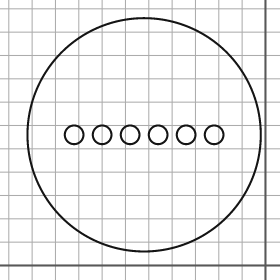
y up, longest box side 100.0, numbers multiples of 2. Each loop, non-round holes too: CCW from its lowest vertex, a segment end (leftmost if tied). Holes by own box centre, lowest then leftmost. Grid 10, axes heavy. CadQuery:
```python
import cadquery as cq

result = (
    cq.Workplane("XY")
    .moveTo(-52.0, 56.0)
    .circle(50.0)
    .moveTo(-82.0, 56.0)
    .circle(4.0)
    .moveTo(-70.0, 56.0)
    .circle(4.0)
    .moveTo(-58.0, 56.0)
    .circle(4.0)
    .moveTo(-46.0, 56.0)
    .circle(4.0)
    .moveTo(-34.0, 56.0)
    .circle(4.0)
    .moveTo(-22.0, 56.0)
    .circle(4.0)
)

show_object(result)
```